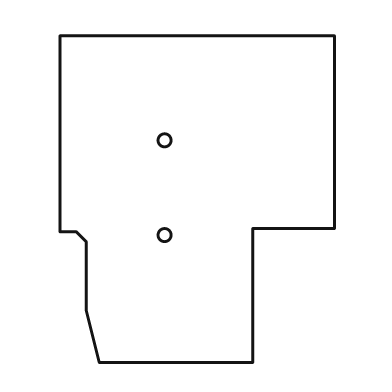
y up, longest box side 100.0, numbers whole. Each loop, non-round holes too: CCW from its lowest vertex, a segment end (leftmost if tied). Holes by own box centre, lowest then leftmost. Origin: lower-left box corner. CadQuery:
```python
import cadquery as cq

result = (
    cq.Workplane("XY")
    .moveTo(12.0, 0.0)
    .lineTo(59.0, 0.0)
    .lineTo(59.0, 41.0)
    .lineTo(84.0, 41.0)
    .lineTo(84.0, 100.0)
    .lineTo(0.0, 100.0)
    .lineTo(0.0, 40.0)
    .lineTo(5.0, 40.0)
    .lineTo(8.0, 37.0)
    .lineTo(8.0, 16.0)
    .close()
    .moveTo(32.0, 39.0)
    .circle(2.0)
    .moveTo(32.0, 68.0)
    .circle(2.0)
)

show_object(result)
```